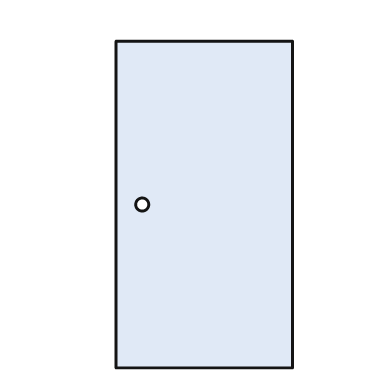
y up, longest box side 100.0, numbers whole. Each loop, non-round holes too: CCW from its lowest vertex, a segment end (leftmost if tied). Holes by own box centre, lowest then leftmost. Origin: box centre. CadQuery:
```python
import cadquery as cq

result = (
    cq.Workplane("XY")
    .moveTo(-27.0, -50.0)
    .lineTo(27.0, -50.0)
    .lineTo(27.0, 50.0)
    .lineTo(-27.0, 50.0)
    .close()
    .moveTo(-19.0, 0.0)
    .circle(2.0)
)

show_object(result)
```